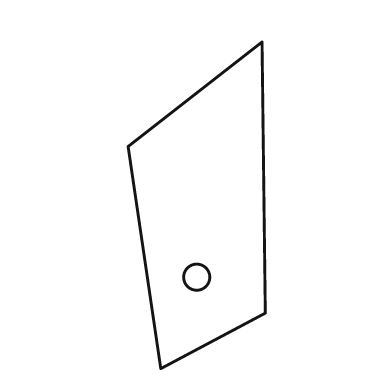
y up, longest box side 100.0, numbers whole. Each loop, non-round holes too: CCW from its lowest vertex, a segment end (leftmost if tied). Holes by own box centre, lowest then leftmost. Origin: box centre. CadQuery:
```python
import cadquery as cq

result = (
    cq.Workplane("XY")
    .moveTo(-11.0, -50.0)
    .lineTo(21.0, -33.0)
    .lineTo(20.0, 50.0)
    .lineTo(-21.0, 18.0)
    .close()
    .moveTo(0.0, -22.0)
    .circle(4.0)
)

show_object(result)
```